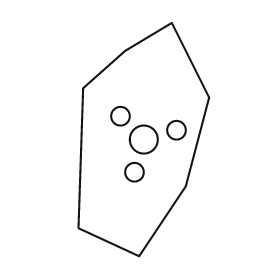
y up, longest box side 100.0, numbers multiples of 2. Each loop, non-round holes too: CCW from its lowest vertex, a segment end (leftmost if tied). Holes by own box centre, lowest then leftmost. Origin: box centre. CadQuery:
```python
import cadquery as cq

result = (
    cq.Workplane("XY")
    .moveTo(-2.0, -50.0)
    .lineTo(18.0, -20.0)
    .lineTo(28.0, 18.0)
    .lineTo(12.0, 50.0)
    .lineTo(-8.0, 38.0)
    .lineTo(-26.0, 22.0)
    .lineTo(-28.0, -38.0)
    .close()
    .moveTo(-4.0, -14.0)
    .circle(4.0)
    .moveTo(0.0, 0.0)
    .circle(6.0)
    .moveTo(14.0, 4.0)
    .circle(4.0)
    .moveTo(-10.0, 10.0)
    .circle(4.0)
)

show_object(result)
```